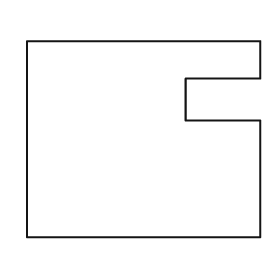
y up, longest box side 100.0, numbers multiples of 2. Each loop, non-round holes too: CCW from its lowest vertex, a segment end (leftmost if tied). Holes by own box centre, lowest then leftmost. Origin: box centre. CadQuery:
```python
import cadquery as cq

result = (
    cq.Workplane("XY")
    .moveTo(-50.0, -42.0)
    .lineTo(50.0, -42.0)
    .lineTo(50.0, 8.0)
    .lineTo(18.0, 8.0)
    .lineTo(18.0, 26.0)
    .lineTo(50.0, 26.0)
    .lineTo(50.0, 42.0)
    .lineTo(-50.0, 42.0)
    .close()
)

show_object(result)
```